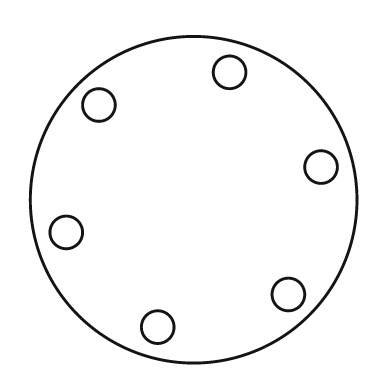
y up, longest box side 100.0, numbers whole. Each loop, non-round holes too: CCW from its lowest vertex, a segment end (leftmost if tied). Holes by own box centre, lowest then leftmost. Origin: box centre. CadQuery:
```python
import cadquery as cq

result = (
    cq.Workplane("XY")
    .moveTo(0.0, 0.0)
    .circle(50.0)
    .moveTo(-11.0, -39.0)
    .circle(5.0)
    .moveTo(29.0, -29.0)
    .circle(5.0)
    .moveTo(-39.0, -10.0)
    .circle(5.0)
    .moveTo(39.0, 10.0)
    .circle(5.0)
    .moveTo(-29.0, 29.0)
    .circle(5.0)
    .moveTo(11.0, 39.0)
    .circle(5.0)
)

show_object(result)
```